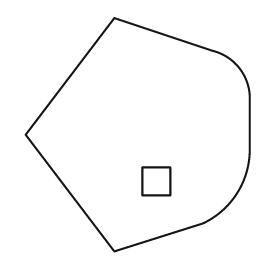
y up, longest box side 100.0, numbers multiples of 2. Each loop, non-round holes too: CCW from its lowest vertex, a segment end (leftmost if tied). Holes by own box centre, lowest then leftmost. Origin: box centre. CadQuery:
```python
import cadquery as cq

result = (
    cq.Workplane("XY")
    .moveTo(-10.0, -50.0)
    .lineTo(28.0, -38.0)
    .threePointArc((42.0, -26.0), (48.0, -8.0))
    .lineTo(48.0, 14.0)
    .threePointArc((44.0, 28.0), (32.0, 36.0))
    .lineTo(-10.0, 50.0)
    .lineTo(-48.0, 0.0)
    .close()
    .moveTo(2.0, -26.0)
    .lineTo(14.0, -26.0)
    .lineTo(14.0, -14.0)
    .lineTo(2.0, -14.0)
    .close()
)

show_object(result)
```